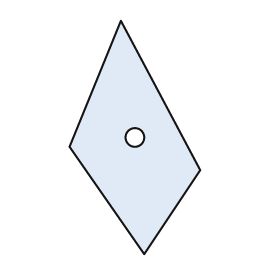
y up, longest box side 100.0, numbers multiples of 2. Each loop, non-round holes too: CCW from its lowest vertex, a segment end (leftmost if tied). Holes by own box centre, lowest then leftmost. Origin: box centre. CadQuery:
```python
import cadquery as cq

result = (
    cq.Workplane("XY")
    .moveTo(4.0, -50.0)
    .lineTo(28.0, -14.0)
    .lineTo(-6.0, 50.0)
    .lineTo(-28.0, -4.0)
    .close()
    .moveTo(0.0, 0.0)
    .circle(4.0)
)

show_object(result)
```